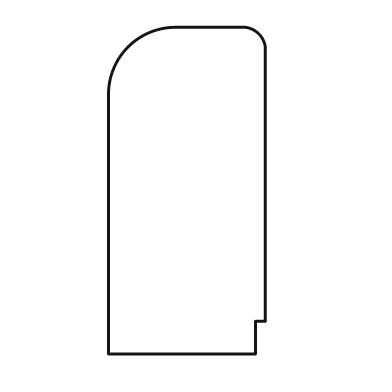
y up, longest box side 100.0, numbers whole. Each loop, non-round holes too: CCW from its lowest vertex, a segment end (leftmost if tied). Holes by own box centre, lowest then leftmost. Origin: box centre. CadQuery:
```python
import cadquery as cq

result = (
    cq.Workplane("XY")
    .moveTo(-24.0, -50.0)
    .lineTo(21.0, -50.0)
    .lineTo(21.0, -40.0)
    .lineTo(24.0, -40.0)
    .lineTo(24.0, 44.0)
    .threePointArc((22.0, 48.0), (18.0, 50.0))
    .lineTo(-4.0, 50.0)
    .threePointArc((-18.0, 44.0), (-24.0, 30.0))
    .close()
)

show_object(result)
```